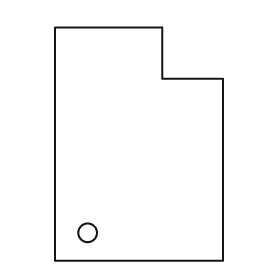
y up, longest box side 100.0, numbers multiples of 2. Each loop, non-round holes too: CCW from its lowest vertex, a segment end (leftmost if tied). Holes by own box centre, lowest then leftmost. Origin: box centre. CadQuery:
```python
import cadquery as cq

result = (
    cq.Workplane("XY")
    .moveTo(-36.0, -50.0)
    .lineTo(36.0, -50.0)
    .lineTo(36.0, 28.0)
    .lineTo(10.0, 28.0)
    .lineTo(10.0, 50.0)
    .lineTo(-36.0, 50.0)
    .close()
    .moveTo(-22.0, -38.0)
    .circle(4.0)
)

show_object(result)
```